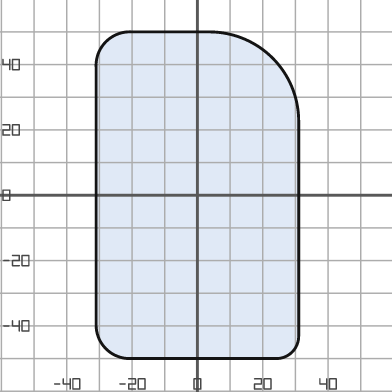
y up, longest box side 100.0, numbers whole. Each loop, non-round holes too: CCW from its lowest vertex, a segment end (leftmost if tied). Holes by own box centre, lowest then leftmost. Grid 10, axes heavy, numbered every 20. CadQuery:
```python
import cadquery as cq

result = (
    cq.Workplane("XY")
    .moveTo(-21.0, -50.0)
    .lineTo(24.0, -50.0)
    .threePointArc((29.0, -48.0), (31.0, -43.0))
    .lineTo(31.0, 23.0)
    .threePointArc((23.0, 42.0), (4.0, 50.0))
    .lineTo(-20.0, 50.0)
    .threePointArc((-28.0, 47.0), (-31.0, 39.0))
    .lineTo(-31.0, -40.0)
    .threePointArc((-28.0, -47.0), (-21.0, -50.0))
    .close()
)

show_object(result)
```